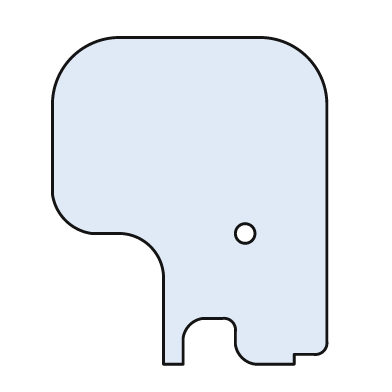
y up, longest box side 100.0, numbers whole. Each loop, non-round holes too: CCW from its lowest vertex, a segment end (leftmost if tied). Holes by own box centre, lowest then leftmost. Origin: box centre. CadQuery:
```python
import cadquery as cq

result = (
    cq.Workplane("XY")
    .moveTo(-8.0, -50.0)
    .lineTo(-2.0, -50.0)
    .lineTo(-2.0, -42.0)
    .threePointArc((0.0, -38.0), (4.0, -36.0))
    .lineTo(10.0, -36.0)
    .threePointArc((13.0, -37.0), (14.0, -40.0))
    .lineTo(14.0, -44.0)
    .threePointArc((16.0, -48.0), (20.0, -50.0))
    .lineTo(32.0, -50.0)
    .lineTo(32.0, -47.0)
    .lineTo(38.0, -47.0)
    .threePointArc((41.0, -46.0), (42.0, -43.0))
    .lineTo(42.0, 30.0)
    .threePointArc((36.0, 44.0), (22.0, 50.0))
    .lineTo(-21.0, 50.0)
    .threePointArc((-36.0, 44.0), (-42.0, 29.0))
    .lineTo(-42.0, 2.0)
    .threePointArc((-38.0, -6.0), (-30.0, -10.0))
    .lineTo(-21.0, -10.0)
    .threePointArc((-12.0, -14.0), (-8.0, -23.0))
    .close()
    .moveTo(17.0, -10.0)
    .circle(3.0)
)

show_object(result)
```